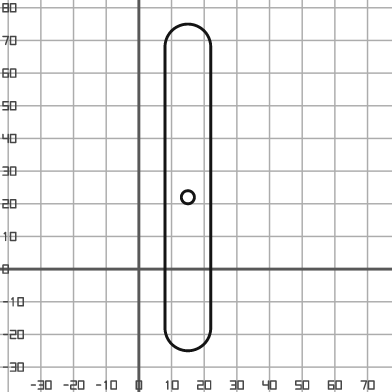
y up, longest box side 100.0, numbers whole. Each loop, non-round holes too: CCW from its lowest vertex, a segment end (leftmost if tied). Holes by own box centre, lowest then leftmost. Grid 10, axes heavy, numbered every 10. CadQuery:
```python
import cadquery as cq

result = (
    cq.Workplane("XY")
    .moveTo(8.0, -18.0)
    .threePointArc((15.0, -25.0), (22.0, -18.0))
    .lineTo(22.0, 68.0)
    .threePointArc((15.0, 75.0), (8.0, 68.0))
    .close()
    .moveTo(15.0, 22.0)
    .circle(2.0)
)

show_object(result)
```